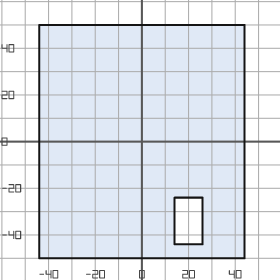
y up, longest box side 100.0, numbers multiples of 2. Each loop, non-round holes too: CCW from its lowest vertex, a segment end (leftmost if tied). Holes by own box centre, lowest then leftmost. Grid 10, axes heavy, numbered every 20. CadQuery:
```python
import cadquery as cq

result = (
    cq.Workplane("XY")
    .moveTo(-44.0, -50.0)
    .lineTo(44.0, -50.0)
    .lineTo(44.0, 50.0)
    .lineTo(-44.0, 50.0)
    .close()
    .moveTo(14.0, -44.0)
    .lineTo(26.0, -44.0)
    .lineTo(26.0, -24.0)
    .lineTo(14.0, -24.0)
    .close()
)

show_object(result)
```